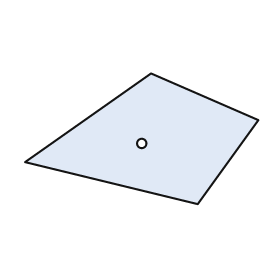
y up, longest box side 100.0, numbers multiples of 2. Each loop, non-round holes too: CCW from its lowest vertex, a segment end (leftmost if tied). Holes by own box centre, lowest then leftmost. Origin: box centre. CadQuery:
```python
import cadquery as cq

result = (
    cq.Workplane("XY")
    .moveTo(24.0, -28.0)
    .lineTo(50.0, 8.0)
    .lineTo(4.0, 28.0)
    .lineTo(-50.0, -10.0)
    .close()
    .moveTo(0.0, -2.0)
    .circle(2.0)
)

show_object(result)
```